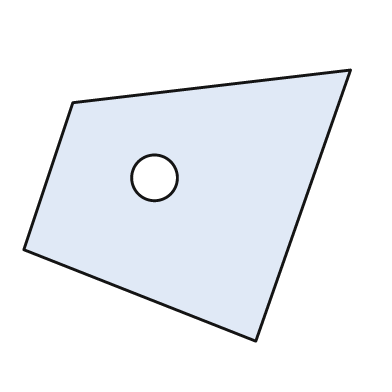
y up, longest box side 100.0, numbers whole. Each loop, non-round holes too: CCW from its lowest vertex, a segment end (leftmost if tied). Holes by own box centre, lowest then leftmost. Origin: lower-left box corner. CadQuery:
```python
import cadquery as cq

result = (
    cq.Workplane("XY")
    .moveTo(71.0, 0.0)
    .lineTo(100.0, 83.0)
    .lineTo(15.0, 73.0)
    .lineTo(0.0, 28.0)
    .close()
    .moveTo(40.0, 50.0)
    .circle(7.0)
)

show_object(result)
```